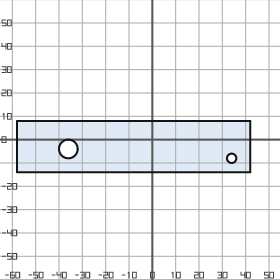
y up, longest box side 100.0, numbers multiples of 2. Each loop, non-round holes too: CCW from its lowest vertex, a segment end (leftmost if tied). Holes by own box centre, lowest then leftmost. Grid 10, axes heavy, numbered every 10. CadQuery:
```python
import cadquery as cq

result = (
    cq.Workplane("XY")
    .moveTo(-58.0, -14.0)
    .lineTo(42.0, -14.0)
    .lineTo(42.0, 8.0)
    .lineTo(-58.0, 8.0)
    .close()
    .moveTo(34.0, -8.0)
    .circle(2.0)
    .moveTo(-36.0, -4.0)
    .circle(4.0)
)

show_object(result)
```